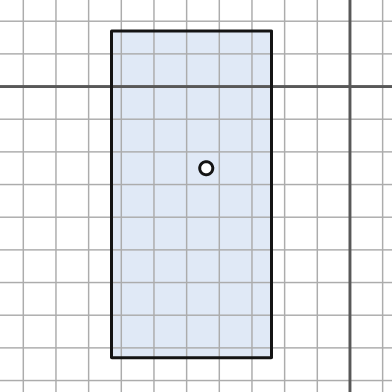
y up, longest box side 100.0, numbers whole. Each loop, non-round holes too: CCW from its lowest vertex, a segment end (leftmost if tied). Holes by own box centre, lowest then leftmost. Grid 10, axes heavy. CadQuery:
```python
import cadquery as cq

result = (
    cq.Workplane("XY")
    .moveTo(-73.0, -83.0)
    .lineTo(-24.0, -83.0)
    .lineTo(-24.0, 17.0)
    .lineTo(-73.0, 17.0)
    .close()
    .moveTo(-44.0, -25.0)
    .circle(2.0)
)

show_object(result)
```